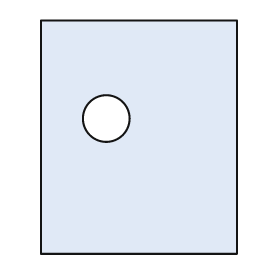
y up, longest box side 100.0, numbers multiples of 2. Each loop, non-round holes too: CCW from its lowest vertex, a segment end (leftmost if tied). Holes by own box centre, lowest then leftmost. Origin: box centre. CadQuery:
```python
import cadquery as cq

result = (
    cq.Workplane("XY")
    .moveTo(-42.0, -50.0)
    .lineTo(42.0, -50.0)
    .lineTo(42.0, 50.0)
    .lineTo(-42.0, 50.0)
    .close()
    .moveTo(-14.0, 8.0)
    .circle(10.0)
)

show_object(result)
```